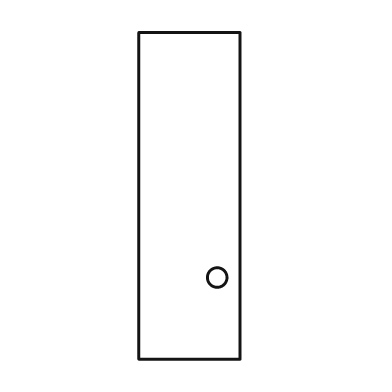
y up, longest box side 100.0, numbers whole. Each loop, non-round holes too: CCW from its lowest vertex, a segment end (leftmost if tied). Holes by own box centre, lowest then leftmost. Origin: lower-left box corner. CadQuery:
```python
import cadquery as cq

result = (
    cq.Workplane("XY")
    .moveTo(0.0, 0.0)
    .lineTo(31.0, 0.0)
    .lineTo(31.0, 100.0)
    .lineTo(0.0, 100.0)
    .close()
    .moveTo(24.0, 25.0)
    .circle(3.0)
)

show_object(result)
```